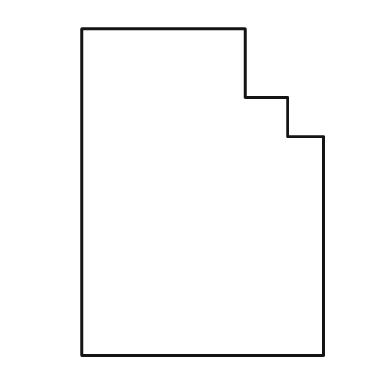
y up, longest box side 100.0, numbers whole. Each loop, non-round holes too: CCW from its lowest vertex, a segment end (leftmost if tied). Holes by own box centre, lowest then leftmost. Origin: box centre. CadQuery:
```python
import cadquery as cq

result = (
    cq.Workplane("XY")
    .moveTo(-37.0, -50.0)
    .lineTo(37.0, -50.0)
    .lineTo(37.0, 17.0)
    .lineTo(26.0, 17.0)
    .lineTo(26.0, 29.0)
    .lineTo(13.0, 29.0)
    .lineTo(13.0, 50.0)
    .lineTo(-37.0, 50.0)
    .close()
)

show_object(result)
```